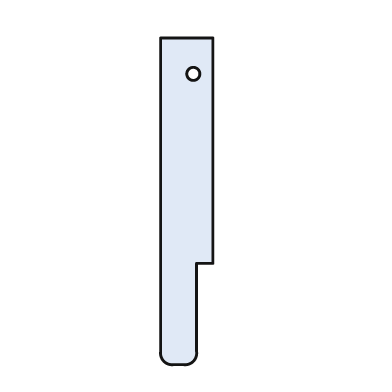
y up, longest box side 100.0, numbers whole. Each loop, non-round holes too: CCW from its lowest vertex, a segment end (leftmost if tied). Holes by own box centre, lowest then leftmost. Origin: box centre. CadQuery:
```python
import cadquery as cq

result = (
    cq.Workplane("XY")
    .moveTo(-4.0, -50.0)
    .lineTo(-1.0, -50.0)
    .threePointArc((2.0, -49.0), (3.0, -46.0))
    .lineTo(3.0, -19.0)
    .lineTo(8.0, -19.0)
    .lineTo(8.0, 50.0)
    .lineTo(-8.0, 50.0)
    .lineTo(-8.0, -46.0)
    .threePointArc((-7.0, -49.0), (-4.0, -50.0))
    .close()
    .moveTo(2.0, 39.0)
    .circle(2.0)
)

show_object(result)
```